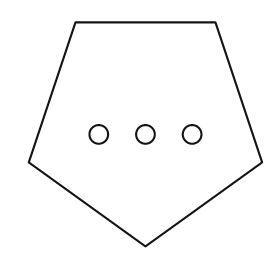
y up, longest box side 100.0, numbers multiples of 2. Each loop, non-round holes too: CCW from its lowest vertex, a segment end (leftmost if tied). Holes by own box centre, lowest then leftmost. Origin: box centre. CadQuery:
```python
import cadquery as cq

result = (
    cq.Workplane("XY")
    .moveTo(0.0, -48.0)
    .lineTo(50.0, -12.0)
    .lineTo(30.0, 48.0)
    .lineTo(-30.0, 48.0)
    .lineTo(-50.0, -12.0)
    .close()
    .moveTo(-20.0, 0.0)
    .circle(4.0)
    .moveTo(0.0, 0.0)
    .circle(4.0)
    .moveTo(20.0, 0.0)
    .circle(4.0)
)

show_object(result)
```